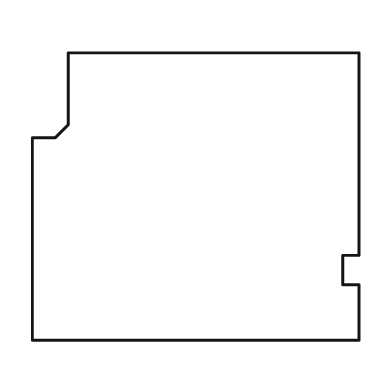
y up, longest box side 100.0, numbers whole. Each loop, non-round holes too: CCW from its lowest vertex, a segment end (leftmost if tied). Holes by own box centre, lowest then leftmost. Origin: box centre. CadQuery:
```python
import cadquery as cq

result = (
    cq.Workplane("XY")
    .moveTo(-50.0, -44.0)
    .lineTo(50.0, -44.0)
    .lineTo(50.0, -27.0)
    .lineTo(45.0, -27.0)
    .lineTo(45.0, -18.0)
    .lineTo(50.0, -18.0)
    .lineTo(50.0, 44.0)
    .lineTo(-39.0, 44.0)
    .lineTo(-39.0, 22.0)
    .lineTo(-43.0, 18.0)
    .lineTo(-50.0, 18.0)
    .close()
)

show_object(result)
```